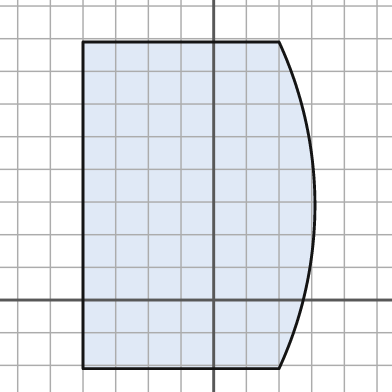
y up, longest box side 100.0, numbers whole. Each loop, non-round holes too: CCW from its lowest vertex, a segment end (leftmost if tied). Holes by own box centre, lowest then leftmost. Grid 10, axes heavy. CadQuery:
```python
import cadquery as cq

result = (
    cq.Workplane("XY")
    .moveTo(-40.0, -21.0)
    .lineTo(20.0, -21.0)
    .threePointArc((31.0, 29.0), (20.0, 79.0))
    .lineTo(-40.0, 79.0)
    .close()
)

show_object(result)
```